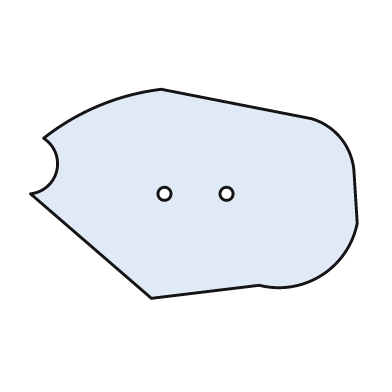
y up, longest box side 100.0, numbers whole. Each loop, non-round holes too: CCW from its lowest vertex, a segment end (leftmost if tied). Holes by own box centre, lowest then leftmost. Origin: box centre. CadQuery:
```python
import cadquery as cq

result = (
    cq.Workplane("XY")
    .moveTo(-13.0, -32.0)
    .lineTo(20.0, -28.0)
    .threePointArc((39.0, -25.0), (50.0, -9.0))
    .lineTo(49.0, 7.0)
    .threePointArc((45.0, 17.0), (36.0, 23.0))
    .lineTo(-10.0, 32.0)
    .threePointArc((-29.0, 27.0), (-46.0, 17.0))
    .threePointArc((-42.0, 7.0), (-50.0, 0.0))
    .close()
    .moveTo(-9.0, 0.0)
    .circle(2.0)
    .moveTo(10.0, 0.0)
    .circle(2.0)
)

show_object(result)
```